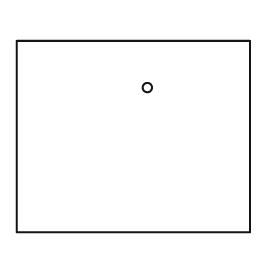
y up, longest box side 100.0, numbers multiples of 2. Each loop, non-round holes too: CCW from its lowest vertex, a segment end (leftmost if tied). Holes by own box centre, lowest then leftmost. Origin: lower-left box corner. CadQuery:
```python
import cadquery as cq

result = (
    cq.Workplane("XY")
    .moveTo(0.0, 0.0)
    .lineTo(100.0, 0.0)
    .lineTo(100.0, 82.0)
    .lineTo(0.0, 82.0)
    .close()
    .moveTo(56.0, 62.0)
    .circle(2.0)
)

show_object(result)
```